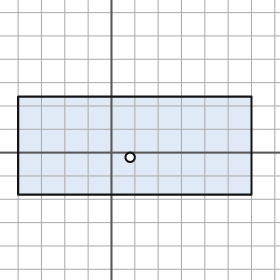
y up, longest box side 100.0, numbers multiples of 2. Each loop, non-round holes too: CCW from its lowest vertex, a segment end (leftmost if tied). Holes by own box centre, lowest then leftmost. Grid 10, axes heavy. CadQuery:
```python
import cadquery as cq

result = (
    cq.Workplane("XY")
    .moveTo(-40.0, -18.0)
    .lineTo(60.0, -18.0)
    .lineTo(60.0, 24.0)
    .lineTo(-40.0, 24.0)
    .close()
    .moveTo(8.0, -2.0)
    .circle(2.0)
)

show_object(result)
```